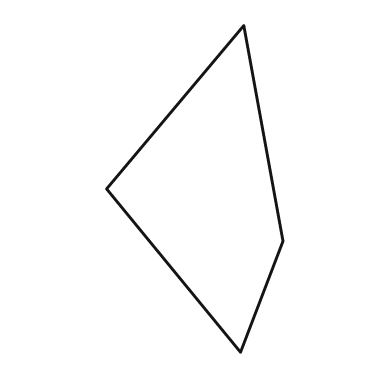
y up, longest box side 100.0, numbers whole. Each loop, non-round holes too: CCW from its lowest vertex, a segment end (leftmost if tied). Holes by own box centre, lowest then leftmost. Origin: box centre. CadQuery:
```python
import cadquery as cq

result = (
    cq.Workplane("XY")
    .moveTo(14.0, -50.0)
    .lineTo(27.0, -16.0)
    .lineTo(15.0, 50.0)
    .lineTo(-27.0, 0.0)
    .close()
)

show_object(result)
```